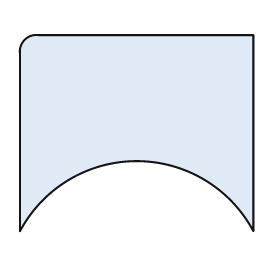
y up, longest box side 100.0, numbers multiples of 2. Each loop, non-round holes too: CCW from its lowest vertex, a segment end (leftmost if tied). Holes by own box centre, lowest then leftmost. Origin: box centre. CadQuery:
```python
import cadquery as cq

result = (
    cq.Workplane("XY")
    .moveTo(-50.0, -42.0)
    .threePointArc((0.0, -12.0), (50.0, -42.0))
    .lineTo(50.0, 42.0)
    .lineTo(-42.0, 42.0)
    .threePointArc((-48.0, 40.0), (-50.0, 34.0))
    .close()
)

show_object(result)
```